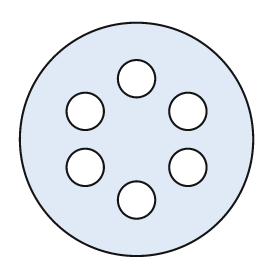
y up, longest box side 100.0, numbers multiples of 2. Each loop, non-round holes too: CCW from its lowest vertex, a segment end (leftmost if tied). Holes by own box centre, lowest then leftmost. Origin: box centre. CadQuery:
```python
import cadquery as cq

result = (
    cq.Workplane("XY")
    .moveTo(0.0, 0.0)
    .circle(50.0)
    .moveTo(0.0, -26.0)
    .circle(8.0)
    .moveTo(-22.0, -12.0)
    .circle(8.0)
    .moveTo(22.0, -12.0)
    .circle(8.0)
    .moveTo(-22.0, 12.0)
    .circle(8.0)
    .moveTo(22.0, 12.0)
    .circle(8.0)
    .moveTo(0.0, 26.0)
    .circle(8.0)
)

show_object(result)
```